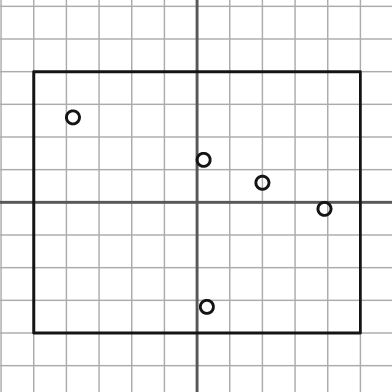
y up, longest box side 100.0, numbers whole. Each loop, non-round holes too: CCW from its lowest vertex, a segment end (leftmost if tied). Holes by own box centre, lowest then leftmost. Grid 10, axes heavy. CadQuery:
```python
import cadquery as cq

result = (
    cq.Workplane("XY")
    .moveTo(-50.0, -40.0)
    .lineTo(50.0, -40.0)
    .lineTo(50.0, 40.0)
    .lineTo(-50.0, 40.0)
    .close()
    .moveTo(3.0, -32.0)
    .circle(2.0)
    .moveTo(39.0, -2.0)
    .circle(2.0)
    .moveTo(20.0, 6.0)
    .circle(2.0)
    .moveTo(2.0, 13.0)
    .circle(2.0)
    .moveTo(-38.0, 26.0)
    .circle(2.0)
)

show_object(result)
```